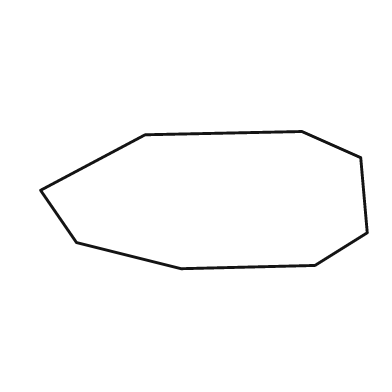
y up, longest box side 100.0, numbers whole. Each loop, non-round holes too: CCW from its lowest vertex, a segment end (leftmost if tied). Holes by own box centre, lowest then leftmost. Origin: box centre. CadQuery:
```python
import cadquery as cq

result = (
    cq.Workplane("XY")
    .moveTo(-7.0, -21.0)
    .lineTo(34.0, -20.0)
    .lineTo(50.0, -10.0)
    .lineTo(48.0, 13.0)
    .lineTo(30.0, 21.0)
    .lineTo(-18.0, 20.0)
    .lineTo(-50.0, 3.0)
    .lineTo(-39.0, -13.0)
    .close()
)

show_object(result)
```